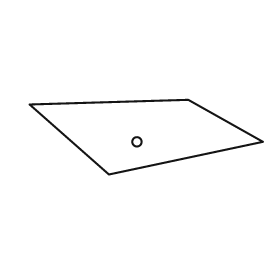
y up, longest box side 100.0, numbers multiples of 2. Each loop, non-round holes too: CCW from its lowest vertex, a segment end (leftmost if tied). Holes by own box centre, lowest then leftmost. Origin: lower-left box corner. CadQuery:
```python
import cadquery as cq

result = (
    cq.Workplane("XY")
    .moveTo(34.0, 0.0)
    .lineTo(100.0, 14.0)
    .lineTo(68.0, 32.0)
    .lineTo(0.0, 30.0)
    .close()
    .moveTo(46.0, 14.0)
    .circle(2.0)
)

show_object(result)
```